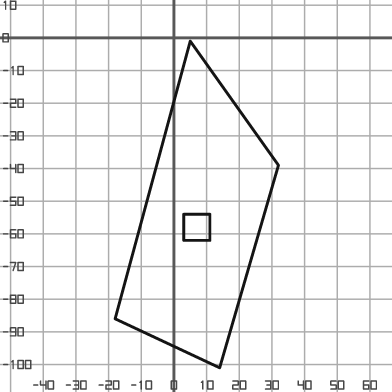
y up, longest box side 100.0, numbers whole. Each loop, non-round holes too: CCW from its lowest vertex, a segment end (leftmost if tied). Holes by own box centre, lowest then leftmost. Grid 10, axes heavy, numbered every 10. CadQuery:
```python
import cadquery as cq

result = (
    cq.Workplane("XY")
    .moveTo(14.0, -101.0)
    .lineTo(32.0, -39.0)
    .lineTo(5.0, -1.0)
    .lineTo(-18.0, -86.0)
    .close()
    .moveTo(3.0, -62.0)
    .lineTo(11.0, -62.0)
    .lineTo(11.0, -54.0)
    .lineTo(3.0, -54.0)
    .close()
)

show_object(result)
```